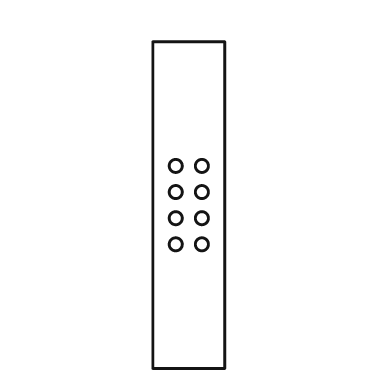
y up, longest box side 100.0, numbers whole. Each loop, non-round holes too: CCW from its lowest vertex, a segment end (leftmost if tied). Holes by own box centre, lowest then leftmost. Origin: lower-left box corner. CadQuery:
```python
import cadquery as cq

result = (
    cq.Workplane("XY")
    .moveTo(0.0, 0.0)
    .lineTo(22.0, 0.0)
    .lineTo(22.0, 100.0)
    .lineTo(0.0, 100.0)
    .close()
    .moveTo(7.0, 38.0)
    .circle(2.0)
    .moveTo(15.0, 38.0)
    .circle(2.0)
    .moveTo(7.0, 46.0)
    .circle(2.0)
    .moveTo(15.0, 46.0)
    .circle(2.0)
    .moveTo(7.0, 54.0)
    .circle(2.0)
    .moveTo(15.0, 54.0)
    .circle(2.0)
    .moveTo(7.0, 62.0)
    .circle(2.0)
    .moveTo(15.0, 62.0)
    .circle(2.0)
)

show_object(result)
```